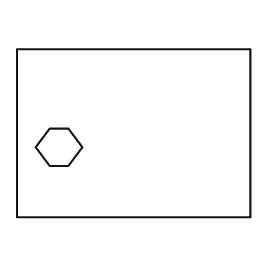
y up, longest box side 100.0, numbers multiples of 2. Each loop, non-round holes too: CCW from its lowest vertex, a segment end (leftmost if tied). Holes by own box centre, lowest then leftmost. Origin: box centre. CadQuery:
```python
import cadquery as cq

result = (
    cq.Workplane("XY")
    .moveTo(-50.0, -36.0)
    .lineTo(50.0, -36.0)
    .lineTo(50.0, 36.0)
    .lineTo(-50.0, 36.0)
    .close()
    .moveTo(-36.0, -14.0)
    .lineTo(-28.0, -14.0)
    .lineTo(-22.0, -6.0)
    .lineTo(-28.0, 2.0)
    .lineTo(-36.0, 2.0)
    .lineTo(-42.0, -6.0)
    .close()
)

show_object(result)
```